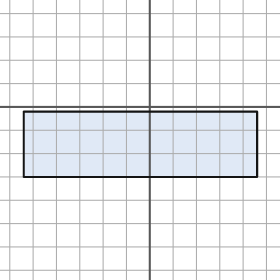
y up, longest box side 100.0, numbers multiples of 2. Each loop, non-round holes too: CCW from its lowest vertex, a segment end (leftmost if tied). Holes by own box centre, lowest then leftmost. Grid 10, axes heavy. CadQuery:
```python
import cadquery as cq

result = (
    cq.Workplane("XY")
    .moveTo(-54.0, -30.0)
    .lineTo(46.0, -30.0)
    .lineTo(46.0, -2.0)
    .lineTo(-54.0, -2.0)
    .close()
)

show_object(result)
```